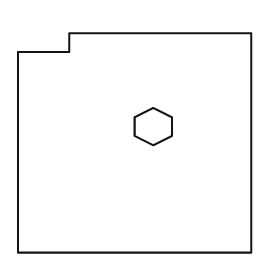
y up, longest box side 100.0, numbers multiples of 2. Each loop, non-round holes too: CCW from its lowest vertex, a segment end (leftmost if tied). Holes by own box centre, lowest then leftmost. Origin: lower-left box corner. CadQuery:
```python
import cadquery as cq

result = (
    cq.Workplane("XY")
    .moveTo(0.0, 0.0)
    .lineTo(100.0, 0.0)
    .lineTo(100.0, 94.0)
    .lineTo(22.0, 94.0)
    .lineTo(22.0, 86.0)
    .lineTo(0.0, 86.0)
    .close()
    .moveTo(58.0, 46.0)
    .lineTo(66.0, 50.0)
    .lineTo(66.0, 58.0)
    .lineTo(58.0, 62.0)
    .lineTo(50.0, 58.0)
    .lineTo(50.0, 50.0)
    .close()
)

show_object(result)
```